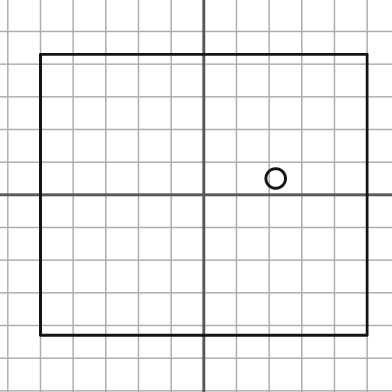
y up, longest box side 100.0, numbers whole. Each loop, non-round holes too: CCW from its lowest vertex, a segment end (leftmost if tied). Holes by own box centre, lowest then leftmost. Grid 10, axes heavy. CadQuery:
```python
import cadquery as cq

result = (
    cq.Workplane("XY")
    .moveTo(-50.0, -43.0)
    .lineTo(50.0, -43.0)
    .lineTo(50.0, 43.0)
    .lineTo(-50.0, 43.0)
    .close()
    .moveTo(22.0, 5.0)
    .circle(3.0)
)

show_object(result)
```